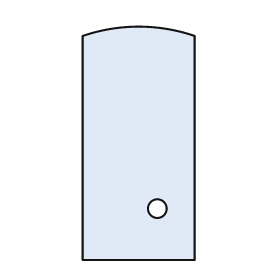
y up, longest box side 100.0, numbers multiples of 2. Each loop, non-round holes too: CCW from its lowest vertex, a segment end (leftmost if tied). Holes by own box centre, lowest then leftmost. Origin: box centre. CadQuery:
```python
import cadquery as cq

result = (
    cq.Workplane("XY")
    .moveTo(-24.0, -50.0)
    .lineTo(24.0, -50.0)
    .lineTo(24.0, 46.0)
    .threePointArc((0.0, 50.0), (-24.0, 46.0))
    .close()
    .moveTo(8.0, -28.0)
    .circle(4.0)
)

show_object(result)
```